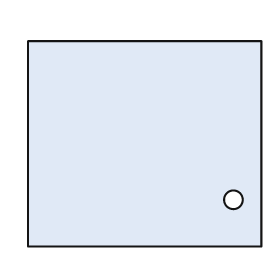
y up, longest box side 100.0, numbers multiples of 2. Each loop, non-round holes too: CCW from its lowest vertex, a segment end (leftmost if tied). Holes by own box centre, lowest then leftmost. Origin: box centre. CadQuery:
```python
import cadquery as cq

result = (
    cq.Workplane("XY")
    .moveTo(-50.0, -44.0)
    .lineTo(50.0, -44.0)
    .lineTo(50.0, 44.0)
    .lineTo(-50.0, 44.0)
    .close()
    .moveTo(38.0, -24.0)
    .circle(4.0)
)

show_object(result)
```